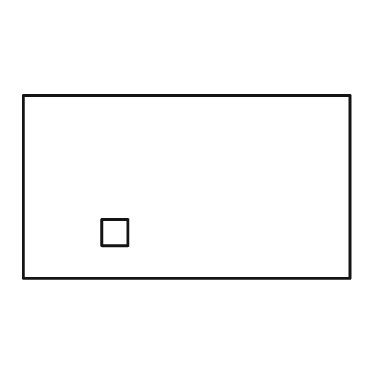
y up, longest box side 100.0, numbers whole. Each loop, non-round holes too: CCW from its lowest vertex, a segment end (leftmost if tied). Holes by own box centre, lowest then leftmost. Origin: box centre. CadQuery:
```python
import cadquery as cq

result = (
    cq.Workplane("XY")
    .moveTo(-50.0, -28.0)
    .lineTo(50.0, -28.0)
    .lineTo(50.0, 28.0)
    .lineTo(-50.0, 28.0)
    .close()
    .moveTo(-26.0, -18.0)
    .lineTo(-18.0, -18.0)
    .lineTo(-18.0, -10.0)
    .lineTo(-26.0, -10.0)
    .close()
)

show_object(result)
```